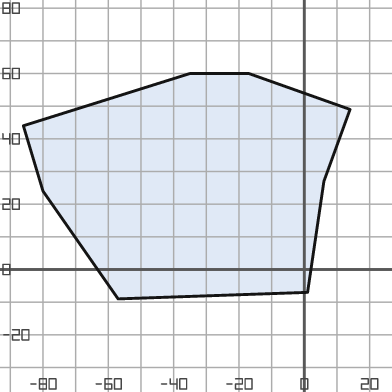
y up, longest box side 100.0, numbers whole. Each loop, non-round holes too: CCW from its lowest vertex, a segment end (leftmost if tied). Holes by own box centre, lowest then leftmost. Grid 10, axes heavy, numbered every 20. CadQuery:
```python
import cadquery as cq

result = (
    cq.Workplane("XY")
    .moveTo(-57.0, -9.0)
    .lineTo(1.0, -7.0)
    .lineTo(6.0, 27.0)
    .lineTo(14.0, 49.0)
    .lineTo(-17.0, 60.0)
    .lineTo(-35.0, 60.0)
    .lineTo(-86.0, 44.0)
    .lineTo(-80.0, 24.0)
    .close()
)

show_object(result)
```